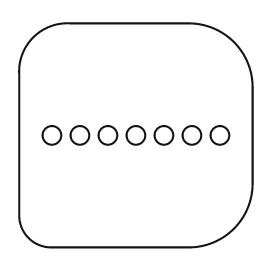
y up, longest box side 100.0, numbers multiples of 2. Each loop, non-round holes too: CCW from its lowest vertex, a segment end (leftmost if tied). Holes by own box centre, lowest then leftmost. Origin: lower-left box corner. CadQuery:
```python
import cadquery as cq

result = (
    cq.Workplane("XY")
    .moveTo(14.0, 0.0)
    .lineTo(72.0, 0.0)
    .threePointArc((92.0, 8.0), (100.0, 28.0))
    .lineTo(100.0, 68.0)
    .threePointArc((92.0, 88.0), (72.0, 96.0))
    .lineTo(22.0, 96.0)
    .threePointArc((6.0, 90.0), (0.0, 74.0))
    .lineTo(0.0, 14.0)
    .threePointArc((4.0, 4.0), (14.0, 0.0))
    .close()
    .moveTo(14.0, 48.0)
    .circle(4.0)
    .moveTo(26.0, 48.0)
    .circle(4.0)
    .moveTo(38.0, 48.0)
    .circle(4.0)
    .moveTo(50.0, 48.0)
    .circle(4.0)
    .moveTo(62.0, 48.0)
    .circle(4.0)
    .moveTo(74.0, 48.0)
    .circle(4.0)
    .moveTo(86.0, 48.0)
    .circle(4.0)
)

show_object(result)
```